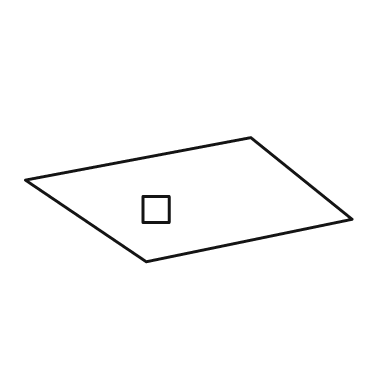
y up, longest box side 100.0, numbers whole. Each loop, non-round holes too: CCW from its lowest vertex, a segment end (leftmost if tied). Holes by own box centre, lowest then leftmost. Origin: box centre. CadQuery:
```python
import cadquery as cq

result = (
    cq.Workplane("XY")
    .moveTo(-13.0, -19.0)
    .lineTo(50.0, -6.0)
    .lineTo(19.0, 19.0)
    .lineTo(-50.0, 6.0)
    .close()
    .moveTo(-14.0, -7.0)
    .lineTo(-6.0, -7.0)
    .lineTo(-6.0, 1.0)
    .lineTo(-14.0, 1.0)
    .close()
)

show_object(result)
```